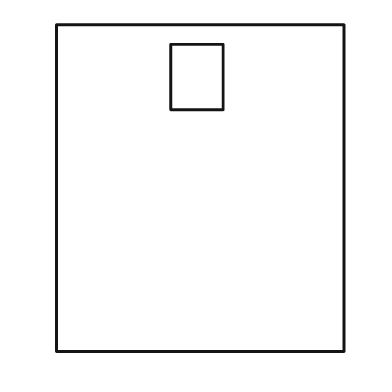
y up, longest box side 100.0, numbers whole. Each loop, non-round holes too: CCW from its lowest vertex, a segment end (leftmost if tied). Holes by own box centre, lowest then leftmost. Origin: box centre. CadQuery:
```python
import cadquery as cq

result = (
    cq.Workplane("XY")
    .moveTo(-44.0, -50.0)
    .lineTo(44.0, -50.0)
    .lineTo(44.0, 50.0)
    .lineTo(-44.0, 50.0)
    .close()
    .moveTo(-9.0, 24.0)
    .lineTo(7.0, 24.0)
    .lineTo(7.0, 44.0)
    .lineTo(-9.0, 44.0)
    .close()
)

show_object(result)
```